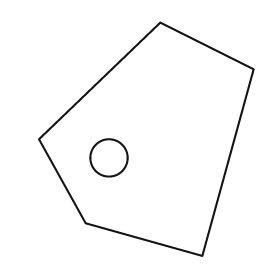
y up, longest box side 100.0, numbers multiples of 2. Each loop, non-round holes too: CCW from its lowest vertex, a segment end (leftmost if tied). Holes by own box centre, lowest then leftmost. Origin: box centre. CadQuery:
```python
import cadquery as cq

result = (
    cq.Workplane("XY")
    .moveTo(24.0, -50.0)
    .lineTo(46.0, 30.0)
    .lineTo(6.0, 50.0)
    .lineTo(-46.0, 0.0)
    .lineTo(-26.0, -36.0)
    .close()
    .moveTo(-16.0, -8.0)
    .circle(8.0)
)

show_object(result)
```